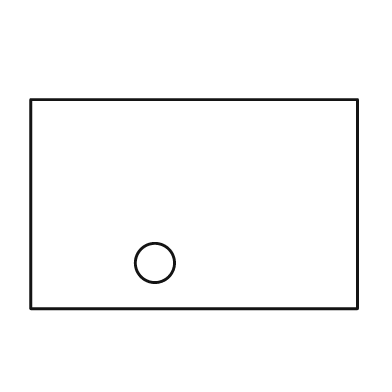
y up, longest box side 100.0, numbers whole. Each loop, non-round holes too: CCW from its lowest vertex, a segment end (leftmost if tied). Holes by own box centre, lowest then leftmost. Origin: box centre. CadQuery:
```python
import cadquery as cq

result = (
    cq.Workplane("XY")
    .moveTo(-50.0, -32.0)
    .lineTo(50.0, -32.0)
    .lineTo(50.0, 32.0)
    .lineTo(-50.0, 32.0)
    .close()
    .moveTo(-12.0, -18.0)
    .circle(6.0)
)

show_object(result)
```